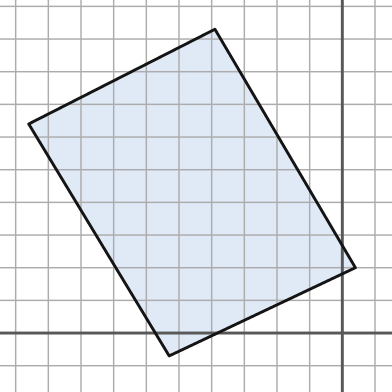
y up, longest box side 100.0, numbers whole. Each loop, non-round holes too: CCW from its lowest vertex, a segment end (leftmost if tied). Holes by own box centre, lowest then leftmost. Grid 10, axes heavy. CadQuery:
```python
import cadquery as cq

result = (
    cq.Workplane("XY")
    .moveTo(-53.0, -7.0)
    .lineTo(4.0, 20.0)
    .lineTo(-39.0, 93.0)
    .lineTo(-96.0, 64.0)
    .close()
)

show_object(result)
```